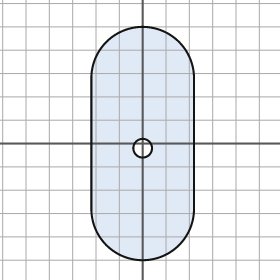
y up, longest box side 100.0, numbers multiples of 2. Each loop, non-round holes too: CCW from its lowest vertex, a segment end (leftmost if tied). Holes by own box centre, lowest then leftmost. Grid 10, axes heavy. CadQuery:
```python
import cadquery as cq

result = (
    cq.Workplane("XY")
    .moveTo(-22.0, -28.0)
    .threePointArc((0.0, -50.0), (22.0, -28.0))
    .lineTo(22.0, 28.0)
    .threePointArc((0.0, 50.0), (-22.0, 28.0))
    .close()
    .moveTo(0.0, -2.0)
    .circle(4.0)
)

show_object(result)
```